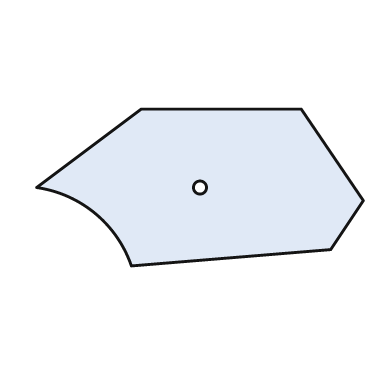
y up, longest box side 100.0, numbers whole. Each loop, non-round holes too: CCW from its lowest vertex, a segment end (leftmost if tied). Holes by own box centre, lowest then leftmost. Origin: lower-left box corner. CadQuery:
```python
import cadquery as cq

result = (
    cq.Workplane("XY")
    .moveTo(29.0, 0.0)
    .lineTo(90.0, 5.0)
    .lineTo(100.0, 20.0)
    .lineTo(81.0, 48.0)
    .lineTo(32.0, 48.0)
    .lineTo(0.0, 24.0)
    .threePointArc((18.0, 16.0), (29.0, 0.0))
    .close()
    .moveTo(50.0, 24.0)
    .circle(2.0)
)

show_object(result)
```